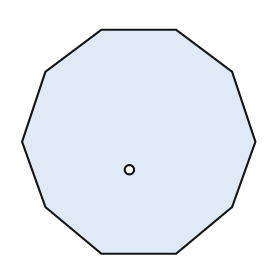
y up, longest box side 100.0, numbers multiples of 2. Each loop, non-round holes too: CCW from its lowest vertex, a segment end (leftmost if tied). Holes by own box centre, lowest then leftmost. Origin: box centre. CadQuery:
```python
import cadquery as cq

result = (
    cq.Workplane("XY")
    .moveTo(-16.0, -48.0)
    .lineTo(16.0, -48.0)
    .lineTo(40.0, -28.0)
    .lineTo(50.0, 0.0)
    .lineTo(40.0, 30.0)
    .lineTo(16.0, 48.0)
    .lineTo(-16.0, 48.0)
    .lineTo(-40.0, 30.0)
    .lineTo(-50.0, 0.0)
    .lineTo(-40.0, -28.0)
    .close()
    .moveTo(-4.0, -12.0)
    .circle(2.0)
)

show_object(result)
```